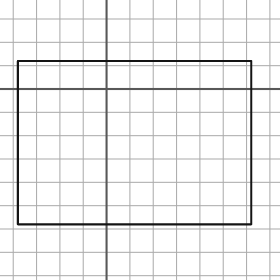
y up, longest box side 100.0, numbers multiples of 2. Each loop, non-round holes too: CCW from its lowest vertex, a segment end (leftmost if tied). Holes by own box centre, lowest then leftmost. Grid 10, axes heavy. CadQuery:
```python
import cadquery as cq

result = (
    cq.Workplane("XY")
    .moveTo(-38.0, -58.0)
    .lineTo(62.0, -58.0)
    .lineTo(62.0, 12.0)
    .lineTo(-38.0, 12.0)
    .close()
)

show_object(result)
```